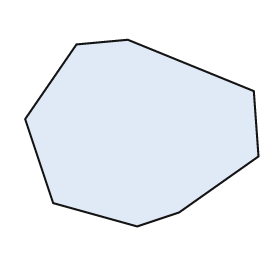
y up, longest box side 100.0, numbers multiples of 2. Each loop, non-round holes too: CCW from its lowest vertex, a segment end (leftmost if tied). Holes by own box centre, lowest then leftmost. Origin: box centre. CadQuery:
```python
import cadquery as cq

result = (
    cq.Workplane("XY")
    .moveTo(-2.0, -40.0)
    .lineTo(16.0, -34.0)
    .lineTo(50.0, -10.0)
    .lineTo(48.0, 18.0)
    .lineTo(-6.0, 40.0)
    .lineTo(-28.0, 38.0)
    .lineTo(-50.0, 6.0)
    .lineTo(-38.0, -30.0)
    .close()
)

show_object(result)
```